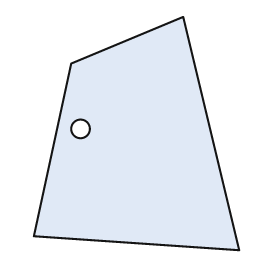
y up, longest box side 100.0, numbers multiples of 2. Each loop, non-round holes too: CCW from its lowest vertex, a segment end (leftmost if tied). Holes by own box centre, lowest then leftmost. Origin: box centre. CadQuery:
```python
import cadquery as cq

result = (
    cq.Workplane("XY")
    .moveTo(44.0, -50.0)
    .lineTo(20.0, 50.0)
    .lineTo(-28.0, 30.0)
    .lineTo(-44.0, -44.0)
    .close()
    .moveTo(-24.0, 2.0)
    .circle(4.0)
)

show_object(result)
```